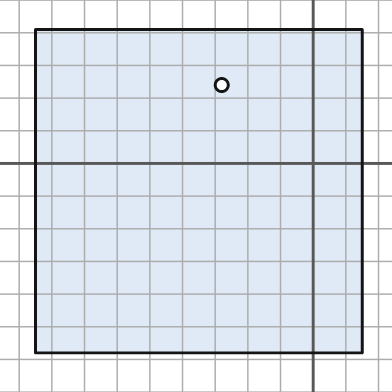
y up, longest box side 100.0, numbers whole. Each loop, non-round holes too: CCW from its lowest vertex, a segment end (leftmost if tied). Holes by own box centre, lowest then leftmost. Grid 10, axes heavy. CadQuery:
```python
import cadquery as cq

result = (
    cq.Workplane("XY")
    .moveTo(-85.0, -58.0)
    .lineTo(15.0, -58.0)
    .lineTo(15.0, 41.0)
    .lineTo(-85.0, 41.0)
    .close()
    .moveTo(-28.0, 24.0)
    .circle(2.0)
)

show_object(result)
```